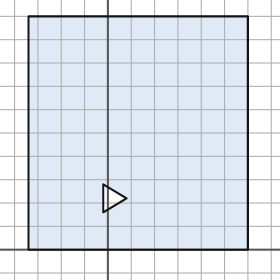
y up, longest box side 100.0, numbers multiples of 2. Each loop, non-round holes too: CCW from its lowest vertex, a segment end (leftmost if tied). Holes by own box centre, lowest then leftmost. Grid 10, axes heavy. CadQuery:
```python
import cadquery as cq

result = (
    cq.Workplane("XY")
    .moveTo(-34.0, 0.0)
    .lineTo(60.0, 0.0)
    .lineTo(60.0, 100.0)
    .lineTo(-34.0, 100.0)
    .close()
    .moveTo(-2.0, 16.0)
    .lineTo(8.0, 22.0)
    .lineTo(-2.0, 28.0)
    .close()
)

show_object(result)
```